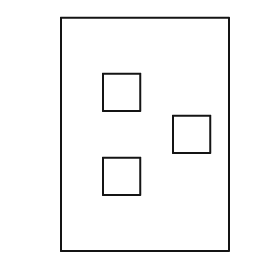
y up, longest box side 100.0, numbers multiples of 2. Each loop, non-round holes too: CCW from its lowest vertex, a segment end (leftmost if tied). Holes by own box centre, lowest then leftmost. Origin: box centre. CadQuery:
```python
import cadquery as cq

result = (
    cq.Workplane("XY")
    .moveTo(-36.0, -50.0)
    .lineTo(36.0, -50.0)
    .lineTo(36.0, 50.0)
    .lineTo(-36.0, 50.0)
    .close()
    .moveTo(-18.0, -26.0)
    .lineTo(-2.0, -26.0)
    .lineTo(-2.0, -10.0)
    .lineTo(-18.0, -10.0)
    .close()
    .moveTo(12.0, -8.0)
    .lineTo(28.0, -8.0)
    .lineTo(28.0, 8.0)
    .lineTo(12.0, 8.0)
    .close()
    .moveTo(-18.0, 10.0)
    .lineTo(-2.0, 10.0)
    .lineTo(-2.0, 26.0)
    .lineTo(-18.0, 26.0)
    .close()
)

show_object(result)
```